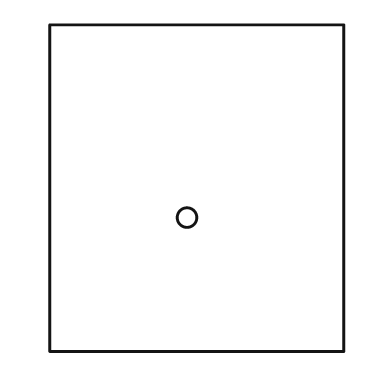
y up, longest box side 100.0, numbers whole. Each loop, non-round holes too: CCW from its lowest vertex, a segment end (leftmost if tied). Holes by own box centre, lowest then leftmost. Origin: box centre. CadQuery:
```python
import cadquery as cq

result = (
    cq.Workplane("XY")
    .moveTo(-45.0, -50.0)
    .lineTo(45.0, -50.0)
    .lineTo(45.0, 50.0)
    .lineTo(-45.0, 50.0)
    .close()
    .moveTo(-3.0, -9.0)
    .circle(3.0)
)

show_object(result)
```